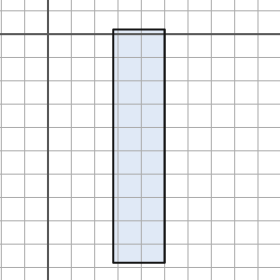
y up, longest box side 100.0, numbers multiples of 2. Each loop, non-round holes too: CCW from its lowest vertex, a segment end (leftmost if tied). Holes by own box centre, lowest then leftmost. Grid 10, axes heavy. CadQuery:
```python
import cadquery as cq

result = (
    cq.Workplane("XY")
    .moveTo(28.0, -98.0)
    .lineTo(50.0, -98.0)
    .lineTo(50.0, 2.0)
    .lineTo(28.0, 2.0)
    .close()
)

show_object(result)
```